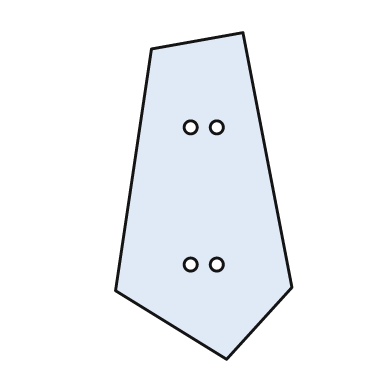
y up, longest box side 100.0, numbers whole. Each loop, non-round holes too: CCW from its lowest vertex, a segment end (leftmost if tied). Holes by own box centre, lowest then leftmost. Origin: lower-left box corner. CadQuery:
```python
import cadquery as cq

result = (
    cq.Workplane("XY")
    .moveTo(34.0, 0.0)
    .lineTo(54.0, 22.0)
    .lineTo(39.0, 100.0)
    .lineTo(11.0, 95.0)
    .lineTo(0.0, 21.0)
    .close()
    .moveTo(23.0, 29.0)
    .circle(2.0)
    .moveTo(31.0, 29.0)
    .circle(2.0)
    .moveTo(23.0, 71.0)
    .circle(2.0)
    .moveTo(31.0, 71.0)
    .circle(2.0)
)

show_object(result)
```